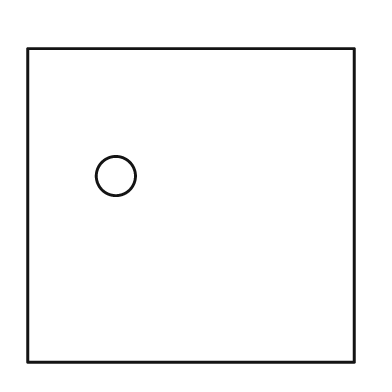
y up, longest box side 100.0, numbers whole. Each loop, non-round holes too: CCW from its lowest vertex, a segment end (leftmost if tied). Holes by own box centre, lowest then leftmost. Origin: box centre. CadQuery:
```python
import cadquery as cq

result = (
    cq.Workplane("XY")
    .moveTo(-50.0, -48.0)
    .lineTo(50.0, -48.0)
    .lineTo(50.0, 48.0)
    .lineTo(-50.0, 48.0)
    .close()
    .moveTo(-23.0, 9.0)
    .circle(6.0)
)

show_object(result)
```